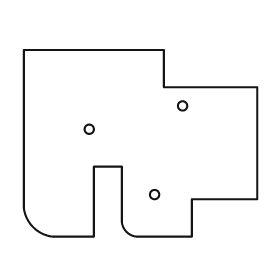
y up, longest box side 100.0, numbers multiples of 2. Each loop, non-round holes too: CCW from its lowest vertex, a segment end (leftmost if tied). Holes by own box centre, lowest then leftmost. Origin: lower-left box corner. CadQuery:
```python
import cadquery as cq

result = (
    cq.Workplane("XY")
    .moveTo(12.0, 0.0)
    .lineTo(30.0, 0.0)
    .lineTo(30.0, 30.0)
    .lineTo(42.0, 30.0)
    .lineTo(42.0, 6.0)
    .threePointArc((44.0, 2.0), (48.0, 0.0))
    .lineTo(72.0, 0.0)
    .lineTo(72.0, 16.0)
    .lineTo(100.0, 16.0)
    .lineTo(100.0, 64.0)
    .lineTo(60.0, 64.0)
    .lineTo(60.0, 80.0)
    .lineTo(0.0, 80.0)
    .lineTo(0.0, 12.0)
    .threePointArc((4.0, 4.0), (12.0, 0.0))
    .close()
    .moveTo(56.0, 18.0)
    .circle(2.0)
    .moveTo(28.0, 46.0)
    .circle(2.0)
    .moveTo(68.0, 56.0)
    .circle(2.0)
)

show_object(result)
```